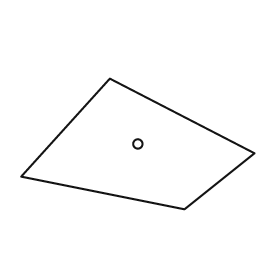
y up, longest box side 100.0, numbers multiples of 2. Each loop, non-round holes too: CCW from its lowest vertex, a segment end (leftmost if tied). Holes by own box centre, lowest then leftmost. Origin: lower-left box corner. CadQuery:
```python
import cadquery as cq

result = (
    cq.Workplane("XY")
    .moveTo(70.0, 0.0)
    .lineTo(100.0, 24.0)
    .lineTo(38.0, 56.0)
    .lineTo(0.0, 14.0)
    .close()
    .moveTo(50.0, 28.0)
    .circle(2.0)
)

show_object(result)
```